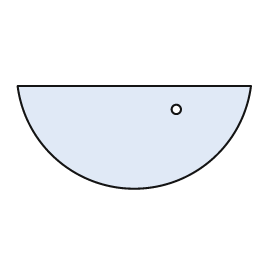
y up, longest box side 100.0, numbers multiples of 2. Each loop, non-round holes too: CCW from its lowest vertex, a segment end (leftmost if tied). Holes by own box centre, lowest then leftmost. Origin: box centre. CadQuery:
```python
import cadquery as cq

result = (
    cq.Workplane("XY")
    .moveTo(-50.0, 22.0)
    .threePointArc((0.0, -22.0), (50.0, 22.0))
    .close()
    .moveTo(18.0, 12.0)
    .circle(2.0)
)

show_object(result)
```